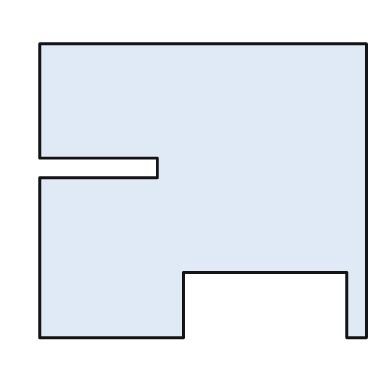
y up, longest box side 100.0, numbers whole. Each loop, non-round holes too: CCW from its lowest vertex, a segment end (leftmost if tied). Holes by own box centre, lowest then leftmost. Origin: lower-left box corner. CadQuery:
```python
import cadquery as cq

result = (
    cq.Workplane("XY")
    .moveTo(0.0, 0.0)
    .lineTo(44.0, 0.0)
    .lineTo(44.0, 20.0)
    .lineTo(94.0, 20.0)
    .lineTo(94.0, 0.0)
    .lineTo(100.0, 0.0)
    .lineTo(100.0, 90.0)
    .lineTo(0.0, 90.0)
    .lineTo(0.0, 55.0)
    .lineTo(36.0, 55.0)
    .lineTo(36.0, 49.0)
    .lineTo(0.0, 49.0)
    .close()
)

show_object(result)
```